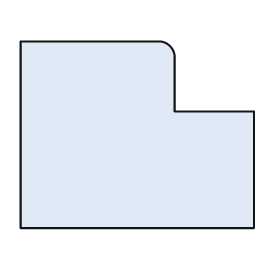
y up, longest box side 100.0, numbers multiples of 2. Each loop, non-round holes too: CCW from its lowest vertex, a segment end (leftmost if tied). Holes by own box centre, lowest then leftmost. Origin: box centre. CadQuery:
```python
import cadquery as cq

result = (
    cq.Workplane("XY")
    .moveTo(-50.0, -40.0)
    .lineTo(50.0, -40.0)
    .lineTo(50.0, 10.0)
    .lineTo(16.0, 10.0)
    .lineTo(16.0, 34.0)
    .threePointArc((14.0, 38.0), (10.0, 40.0))
    .lineTo(-50.0, 40.0)
    .close()
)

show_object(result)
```